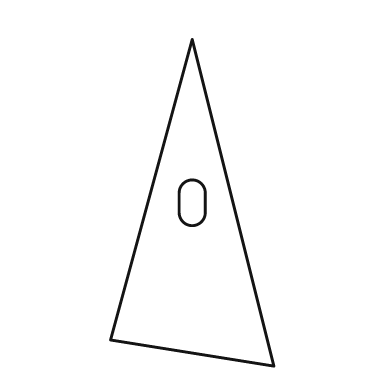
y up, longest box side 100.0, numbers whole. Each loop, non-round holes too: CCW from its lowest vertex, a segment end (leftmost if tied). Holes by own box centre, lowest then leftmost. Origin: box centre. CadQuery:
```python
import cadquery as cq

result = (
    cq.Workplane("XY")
    .moveTo(25.0, -50.0)
    .lineTo(0.0, 50.0)
    .lineTo(-25.0, -42.0)
    .close()
    .moveTo(-4.0, -3.0)
    .threePointArc((0.0, -7.0), (4.0, -3.0))
    .lineTo(4.0, 3.0)
    .threePointArc((0.0, 7.0), (-4.0, 3.0))
    .close()
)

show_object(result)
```